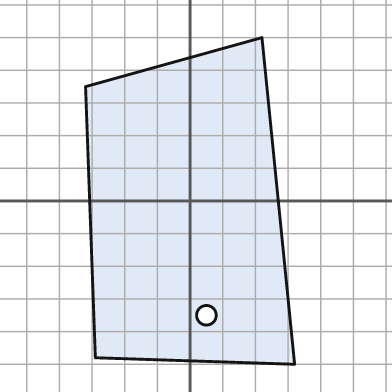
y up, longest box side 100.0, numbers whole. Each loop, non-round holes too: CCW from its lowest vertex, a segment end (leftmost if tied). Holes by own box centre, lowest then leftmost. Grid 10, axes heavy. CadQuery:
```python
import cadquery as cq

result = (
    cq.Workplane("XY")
    .moveTo(32.0, -50.0)
    .lineTo(22.0, 50.0)
    .lineTo(-32.0, 35.0)
    .lineTo(-29.0, -48.0)
    .close()
    .moveTo(5.0, -35.0)
    .circle(3.0)
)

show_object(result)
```